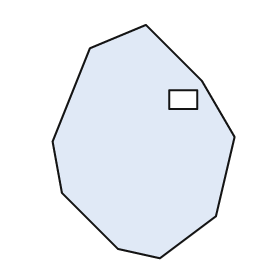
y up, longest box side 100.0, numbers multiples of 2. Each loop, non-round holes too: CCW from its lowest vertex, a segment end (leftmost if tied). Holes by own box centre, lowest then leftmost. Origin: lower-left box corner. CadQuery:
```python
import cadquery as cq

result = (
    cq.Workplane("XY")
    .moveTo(46.0, 0.0)
    .lineTo(70.0, 18.0)
    .lineTo(78.0, 52.0)
    .lineTo(64.0, 76.0)
    .lineTo(40.0, 100.0)
    .lineTo(16.0, 90.0)
    .lineTo(0.0, 50.0)
    .lineTo(4.0, 28.0)
    .lineTo(28.0, 4.0)
    .close()
    .moveTo(50.0, 64.0)
    .lineTo(62.0, 64.0)
    .lineTo(62.0, 72.0)
    .lineTo(50.0, 72.0)
    .close()
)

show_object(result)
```